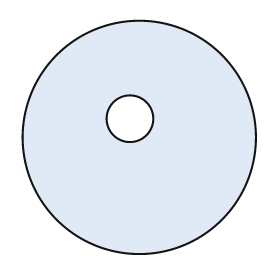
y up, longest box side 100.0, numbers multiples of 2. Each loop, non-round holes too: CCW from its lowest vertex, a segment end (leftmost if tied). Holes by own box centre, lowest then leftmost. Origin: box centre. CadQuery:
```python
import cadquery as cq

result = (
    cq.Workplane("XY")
    .moveTo(0.0, 0.0)
    .circle(50.0)
    .moveTo(-4.0, 8.0)
    .circle(10.0)
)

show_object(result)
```